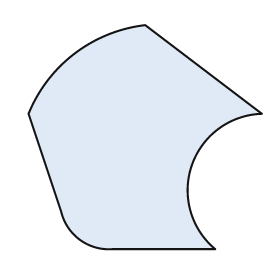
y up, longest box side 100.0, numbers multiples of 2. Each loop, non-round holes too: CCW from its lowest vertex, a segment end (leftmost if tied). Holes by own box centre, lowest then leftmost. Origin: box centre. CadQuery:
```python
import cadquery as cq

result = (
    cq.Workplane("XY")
    .moveTo(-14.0, -48.0)
    .lineTo(30.0, -48.0)
    .threePointArc((20.0, -12.0), (50.0, 10.0))
    .lineTo(0.0, 48.0)
    .threePointArc((-30.0, 36.0), (-50.0, 10.0))
    .lineTo(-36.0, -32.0)
    .threePointArc((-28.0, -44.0), (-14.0, -48.0))
    .close()
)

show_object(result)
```